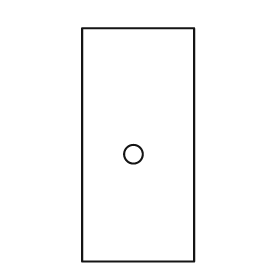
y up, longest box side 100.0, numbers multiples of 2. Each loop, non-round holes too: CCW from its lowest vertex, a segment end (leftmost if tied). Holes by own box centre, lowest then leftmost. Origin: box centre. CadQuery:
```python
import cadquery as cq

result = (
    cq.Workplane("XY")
    .moveTo(-24.0, -50.0)
    .lineTo(24.0, -50.0)
    .lineTo(24.0, 50.0)
    .lineTo(-24.0, 50.0)
    .close()
    .moveTo(-2.0, -4.0)
    .circle(4.0)
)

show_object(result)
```